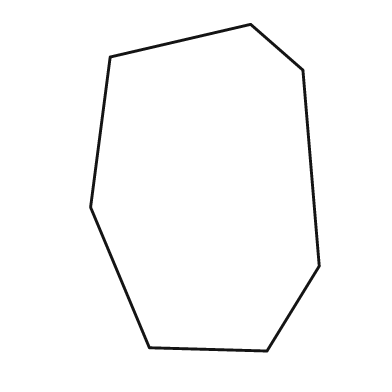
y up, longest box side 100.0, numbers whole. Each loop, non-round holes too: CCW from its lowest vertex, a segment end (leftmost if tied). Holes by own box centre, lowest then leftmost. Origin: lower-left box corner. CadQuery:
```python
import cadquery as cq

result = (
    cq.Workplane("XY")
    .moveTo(54.0, 0.0)
    .lineTo(70.0, 26.0)
    .lineTo(65.0, 86.0)
    .lineTo(49.0, 100.0)
    .lineTo(6.0, 90.0)
    .lineTo(0.0, 44.0)
    .lineTo(18.0, 1.0)
    .close()
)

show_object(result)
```